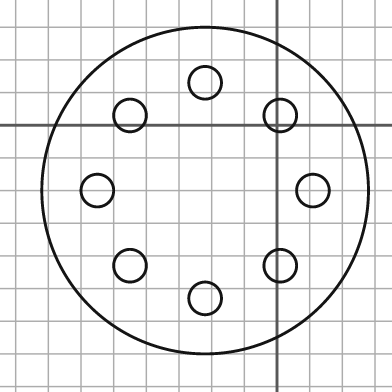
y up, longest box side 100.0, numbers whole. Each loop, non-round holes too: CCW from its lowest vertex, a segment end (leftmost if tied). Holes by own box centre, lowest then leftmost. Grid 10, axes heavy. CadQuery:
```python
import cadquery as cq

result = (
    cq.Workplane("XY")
    .moveTo(-22.0, -20.0)
    .circle(50.0)
    .moveTo(-22.0, -53.0)
    .circle(5.0)
    .moveTo(-45.0, -43.0)
    .circle(5.0)
    .moveTo(1.0, -43.0)
    .circle(5.0)
    .moveTo(-55.0, -20.0)
    .circle(5.0)
    .moveTo(11.0, -20.0)
    .circle(5.0)
    .moveTo(-45.0, 3.0)
    .circle(5.0)
    .moveTo(1.0, 3.0)
    .circle(5.0)
    .moveTo(-22.0, 13.0)
    .circle(5.0)
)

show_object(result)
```